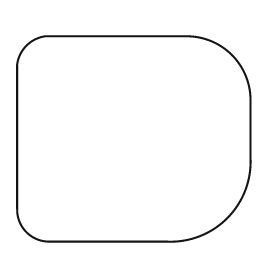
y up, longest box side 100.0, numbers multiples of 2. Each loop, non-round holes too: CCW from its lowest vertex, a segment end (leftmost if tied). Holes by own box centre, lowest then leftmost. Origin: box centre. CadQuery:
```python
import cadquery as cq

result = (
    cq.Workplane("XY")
    .moveTo(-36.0, -44.0)
    .lineTo(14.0, -44.0)
    .threePointArc((40.0, -34.0), (50.0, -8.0))
    .lineTo(50.0, 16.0)
    .threePointArc((42.0, 36.0), (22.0, 44.0))
    .lineTo(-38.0, 44.0)
    .threePointArc((-46.0, 40.0), (-50.0, 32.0))
    .lineTo(-50.0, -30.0)
    .threePointArc((-46.0, -40.0), (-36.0, -44.0))
    .close()
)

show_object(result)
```